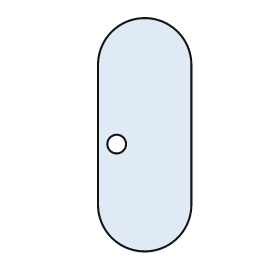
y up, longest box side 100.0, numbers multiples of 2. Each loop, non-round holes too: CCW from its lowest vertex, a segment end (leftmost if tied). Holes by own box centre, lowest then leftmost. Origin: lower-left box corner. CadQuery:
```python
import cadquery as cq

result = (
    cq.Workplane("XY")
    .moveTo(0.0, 20.0)
    .threePointArc((20.0, 0.0), (40.0, 20.0))
    .lineTo(40.0, 80.0)
    .threePointArc((20.0, 100.0), (0.0, 80.0))
    .close()
    .moveTo(8.0, 46.0)
    .circle(4.0)
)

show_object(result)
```